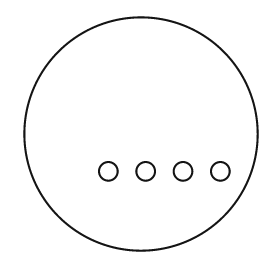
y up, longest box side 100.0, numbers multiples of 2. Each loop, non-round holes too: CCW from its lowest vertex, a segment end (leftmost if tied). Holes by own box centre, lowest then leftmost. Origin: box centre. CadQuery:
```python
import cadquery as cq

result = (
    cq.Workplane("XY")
    .moveTo(0.0, 0.0)
    .circle(50.0)
    .moveTo(-14.0, -16.0)
    .circle(4.0)
    .moveTo(2.0, -16.0)
    .circle(4.0)
    .moveTo(18.0, -16.0)
    .circle(4.0)
    .moveTo(34.0, -16.0)
    .circle(4.0)
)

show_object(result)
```